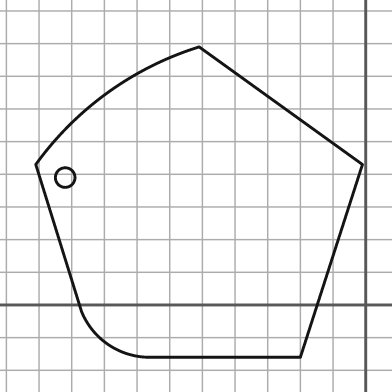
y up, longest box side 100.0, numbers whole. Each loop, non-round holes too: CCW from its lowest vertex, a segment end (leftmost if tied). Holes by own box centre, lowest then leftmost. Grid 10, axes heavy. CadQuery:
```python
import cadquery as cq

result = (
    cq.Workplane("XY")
    .moveTo(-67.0, -16.0)
    .lineTo(-20.0, -16.0)
    .lineTo(-1.0, 43.0)
    .lineTo(-51.0, 79.0)
    .threePointArc((-79.0, 65.0), (-101.0, 43.0))
    .lineTo(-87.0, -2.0)
    .threePointArc((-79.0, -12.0), (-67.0, -16.0))
    .close()
    .moveTo(-92.0, 39.0)
    .circle(3.0)
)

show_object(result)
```